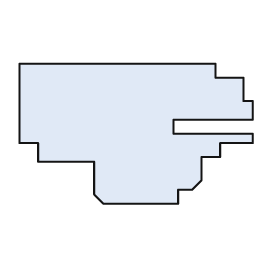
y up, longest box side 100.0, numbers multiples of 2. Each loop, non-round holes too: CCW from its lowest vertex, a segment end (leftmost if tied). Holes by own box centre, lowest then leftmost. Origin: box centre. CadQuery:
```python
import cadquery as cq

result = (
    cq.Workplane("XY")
    .moveTo(-14.0, -30.0)
    .lineTo(18.0, -30.0)
    .lineTo(18.0, -24.0)
    .lineTo(24.0, -24.0)
    .lineTo(28.0, -20.0)
    .lineTo(28.0, -10.0)
    .lineTo(36.0, -10.0)
    .lineTo(36.0, -4.0)
    .lineTo(50.0, -4.0)
    .lineTo(50.0, 0.0)
    .lineTo(16.0, 0.0)
    .lineTo(16.0, 6.0)
    .lineTo(50.0, 6.0)
    .lineTo(50.0, 14.0)
    .lineTo(46.0, 14.0)
    .lineTo(46.0, 24.0)
    .lineTo(34.0, 24.0)
    .lineTo(34.0, 30.0)
    .lineTo(-50.0, 30.0)
    .lineTo(-50.0, -4.0)
    .lineTo(-42.0, -4.0)
    .lineTo(-42.0, -12.0)
    .lineTo(-18.0, -12.0)
    .lineTo(-18.0, -26.0)
    .close()
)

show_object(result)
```